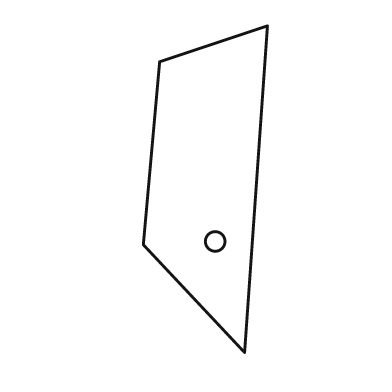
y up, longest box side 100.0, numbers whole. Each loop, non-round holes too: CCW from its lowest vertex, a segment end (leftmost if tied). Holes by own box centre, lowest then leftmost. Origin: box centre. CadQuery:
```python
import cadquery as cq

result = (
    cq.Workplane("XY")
    .moveTo(12.0, -50.0)
    .lineTo(19.0, 50.0)
    .lineTo(-14.0, 39.0)
    .lineTo(-19.0, -17.0)
    .close()
    .moveTo(3.0, -16.0)
    .circle(3.0)
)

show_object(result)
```